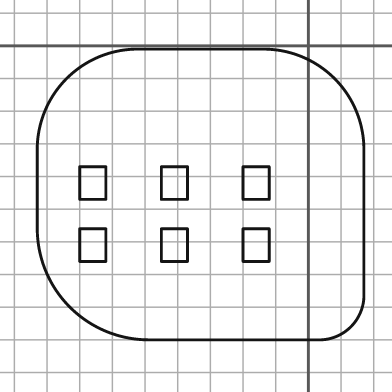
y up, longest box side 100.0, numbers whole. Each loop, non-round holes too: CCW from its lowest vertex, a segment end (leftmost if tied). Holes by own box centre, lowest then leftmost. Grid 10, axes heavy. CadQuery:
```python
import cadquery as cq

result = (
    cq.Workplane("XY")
    .moveTo(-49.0, -90.0)
    .lineTo(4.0, -90.0)
    .threePointArc((13.0, -86.0), (17.0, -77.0))
    .lineTo(17.0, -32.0)
    .threePointArc((8.0, -10.0), (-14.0, -1.0))
    .lineTo(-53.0, -1.0)
    .threePointArc((-74.0, -10.0), (-83.0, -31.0))
    .lineTo(-83.0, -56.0)
    .threePointArc((-73.0, -80.0), (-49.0, -90.0))
    .close()
    .moveTo(-70.0, -66.0)
    .lineTo(-62.0, -66.0)
    .lineTo(-62.0, -56.0)
    .lineTo(-70.0, -56.0)
    .close()
    .moveTo(-45.0, -66.0)
    .lineTo(-37.0, -66.0)
    .lineTo(-37.0, -56.0)
    .lineTo(-45.0, -56.0)
    .close()
    .moveTo(-20.0, -66.0)
    .lineTo(-12.0, -66.0)
    .lineTo(-12.0, -56.0)
    .lineTo(-20.0, -56.0)
    .close()
    .moveTo(-70.0, -47.0)
    .lineTo(-62.0, -47.0)
    .lineTo(-62.0, -37.0)
    .lineTo(-70.0, -37.0)
    .close()
    .moveTo(-45.0, -47.0)
    .lineTo(-37.0, -47.0)
    .lineTo(-37.0, -37.0)
    .lineTo(-45.0, -37.0)
    .close()
    .moveTo(-20.0, -47.0)
    .lineTo(-12.0, -47.0)
    .lineTo(-12.0, -37.0)
    .lineTo(-20.0, -37.0)
    .close()
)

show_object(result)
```